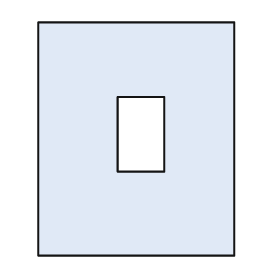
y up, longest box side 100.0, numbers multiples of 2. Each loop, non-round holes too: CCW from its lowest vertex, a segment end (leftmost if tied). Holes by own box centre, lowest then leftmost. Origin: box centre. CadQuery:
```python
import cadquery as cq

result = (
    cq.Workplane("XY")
    .moveTo(-42.0, -50.0)
    .lineTo(42.0, -50.0)
    .lineTo(42.0, 50.0)
    .lineTo(-42.0, 50.0)
    .close()
    .moveTo(-8.0, -14.0)
    .lineTo(12.0, -14.0)
    .lineTo(12.0, 18.0)
    .lineTo(-8.0, 18.0)
    .close()
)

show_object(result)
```